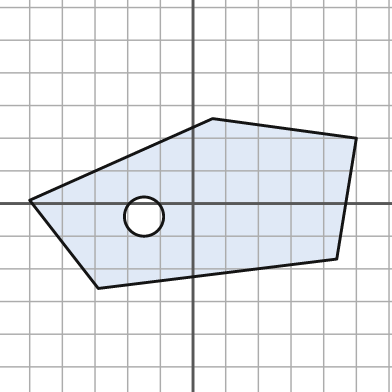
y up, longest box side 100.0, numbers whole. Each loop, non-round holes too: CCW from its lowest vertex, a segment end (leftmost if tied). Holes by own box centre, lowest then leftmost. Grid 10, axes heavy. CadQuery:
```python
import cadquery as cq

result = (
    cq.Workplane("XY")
    .moveTo(-29.0, -26.0)
    .lineTo(44.0, -17.0)
    .lineTo(50.0, 20.0)
    .lineTo(6.0, 26.0)
    .lineTo(-50.0, 1.0)
    .close()
    .moveTo(-15.0, -4.0)
    .circle(6.0)
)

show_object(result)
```